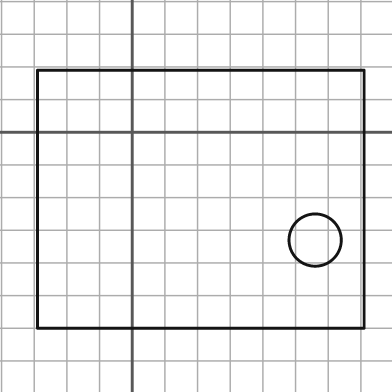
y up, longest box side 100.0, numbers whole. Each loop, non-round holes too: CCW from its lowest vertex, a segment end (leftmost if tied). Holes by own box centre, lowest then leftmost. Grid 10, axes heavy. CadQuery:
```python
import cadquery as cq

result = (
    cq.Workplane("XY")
    .moveTo(-29.0, -60.0)
    .lineTo(71.0, -60.0)
    .lineTo(71.0, 19.0)
    .lineTo(-29.0, 19.0)
    .close()
    .moveTo(56.0, -33.0)
    .circle(8.0)
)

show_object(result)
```